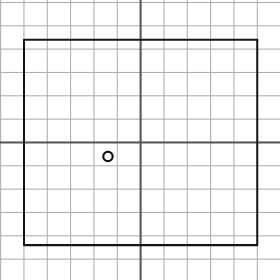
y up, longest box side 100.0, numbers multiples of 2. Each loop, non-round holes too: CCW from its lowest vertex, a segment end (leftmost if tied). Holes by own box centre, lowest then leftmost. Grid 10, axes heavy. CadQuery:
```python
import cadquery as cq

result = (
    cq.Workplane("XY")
    .moveTo(-50.0, -44.0)
    .lineTo(50.0, -44.0)
    .lineTo(50.0, 44.0)
    .lineTo(-50.0, 44.0)
    .close()
    .moveTo(-14.0, -6.0)
    .circle(2.0)
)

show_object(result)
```